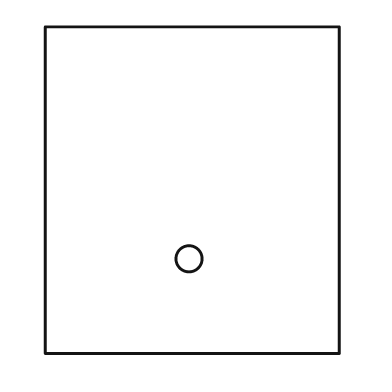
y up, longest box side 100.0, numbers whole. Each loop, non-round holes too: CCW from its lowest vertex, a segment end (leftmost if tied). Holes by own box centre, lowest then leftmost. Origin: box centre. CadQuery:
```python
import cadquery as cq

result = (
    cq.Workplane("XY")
    .moveTo(-45.0, -50.0)
    .lineTo(45.0, -50.0)
    .lineTo(45.0, 50.0)
    .lineTo(-45.0, 50.0)
    .close()
    .moveTo(-1.0, -21.0)
    .circle(4.0)
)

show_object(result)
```